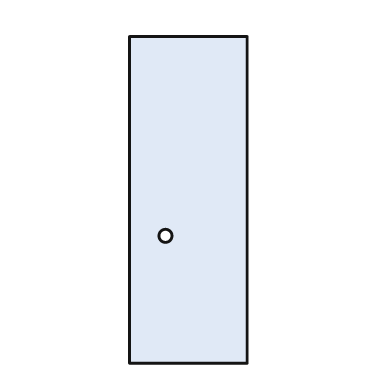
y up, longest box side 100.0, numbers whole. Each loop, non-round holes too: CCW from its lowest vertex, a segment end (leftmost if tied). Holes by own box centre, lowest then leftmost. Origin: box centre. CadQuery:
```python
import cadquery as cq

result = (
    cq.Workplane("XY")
    .moveTo(-18.0, -50.0)
    .lineTo(18.0, -50.0)
    .lineTo(18.0, 50.0)
    .lineTo(-18.0, 50.0)
    .close()
    .moveTo(-7.0, -11.0)
    .circle(2.0)
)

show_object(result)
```